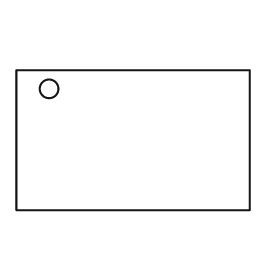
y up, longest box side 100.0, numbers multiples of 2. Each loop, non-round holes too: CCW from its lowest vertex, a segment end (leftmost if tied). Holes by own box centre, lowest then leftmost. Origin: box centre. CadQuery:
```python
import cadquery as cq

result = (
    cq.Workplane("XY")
    .moveTo(-50.0, -30.0)
    .lineTo(50.0, -30.0)
    .lineTo(50.0, 30.0)
    .lineTo(-50.0, 30.0)
    .close()
    .moveTo(-36.0, 22.0)
    .circle(4.0)
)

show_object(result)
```